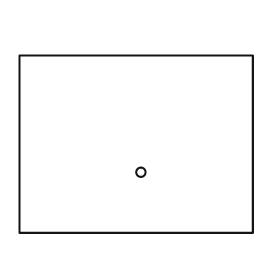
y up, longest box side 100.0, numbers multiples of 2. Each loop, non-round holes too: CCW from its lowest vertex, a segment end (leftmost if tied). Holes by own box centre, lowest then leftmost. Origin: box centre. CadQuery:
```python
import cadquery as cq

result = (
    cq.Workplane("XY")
    .moveTo(-50.0, -38.0)
    .lineTo(50.0, -38.0)
    .lineTo(50.0, 38.0)
    .lineTo(-50.0, 38.0)
    .close()
    .moveTo(2.0, -12.0)
    .circle(2.0)
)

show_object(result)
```